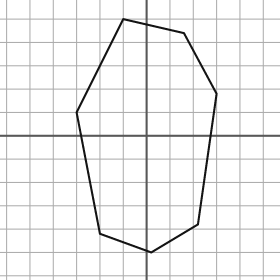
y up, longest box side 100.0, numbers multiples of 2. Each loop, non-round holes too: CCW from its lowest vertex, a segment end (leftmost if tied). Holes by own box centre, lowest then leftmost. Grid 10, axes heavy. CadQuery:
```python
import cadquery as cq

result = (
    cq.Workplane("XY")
    .moveTo(2.0, -50.0)
    .lineTo(22.0, -38.0)
    .lineTo(30.0, 18.0)
    .lineTo(16.0, 44.0)
    .lineTo(-10.0, 50.0)
    .lineTo(-30.0, 10.0)
    .lineTo(-20.0, -42.0)
    .close()
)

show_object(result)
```